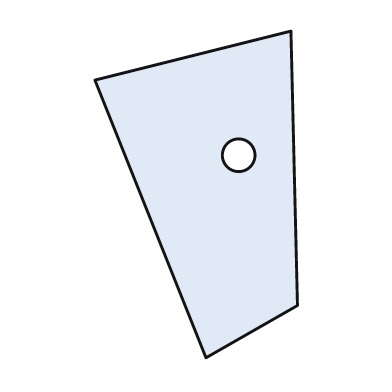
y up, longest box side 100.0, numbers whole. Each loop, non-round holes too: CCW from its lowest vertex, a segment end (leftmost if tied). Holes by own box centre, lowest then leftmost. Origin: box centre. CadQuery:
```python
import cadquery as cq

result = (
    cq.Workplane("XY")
    .moveTo(3.0, -50.0)
    .lineTo(31.0, -34.0)
    .lineTo(29.0, 50.0)
    .lineTo(-31.0, 35.0)
    .close()
    .moveTo(13.0, 12.0)
    .circle(5.0)
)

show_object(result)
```